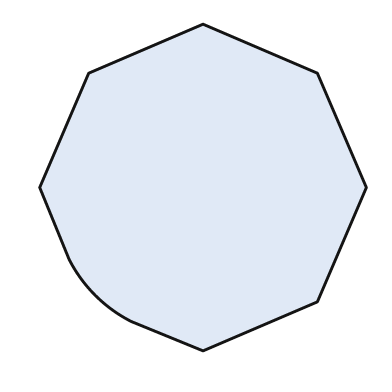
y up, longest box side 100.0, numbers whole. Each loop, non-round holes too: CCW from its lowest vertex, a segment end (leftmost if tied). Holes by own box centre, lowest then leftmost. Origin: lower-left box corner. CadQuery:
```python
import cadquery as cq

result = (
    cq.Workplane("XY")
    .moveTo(50.0, 0.0)
    .lineTo(85.0, 15.0)
    .lineTo(100.0, 50.0)
    .lineTo(85.0, 85.0)
    .lineTo(50.0, 100.0)
    .lineTo(15.0, 85.0)
    .lineTo(0.0, 50.0)
    .lineTo(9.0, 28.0)
    .threePointArc((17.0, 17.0), (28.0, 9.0))
    .close()
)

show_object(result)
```